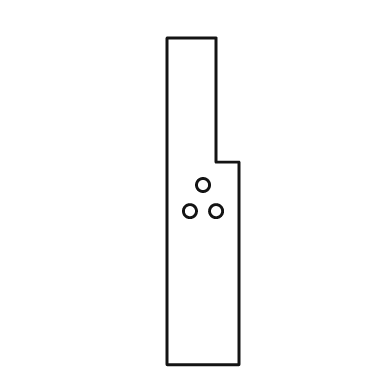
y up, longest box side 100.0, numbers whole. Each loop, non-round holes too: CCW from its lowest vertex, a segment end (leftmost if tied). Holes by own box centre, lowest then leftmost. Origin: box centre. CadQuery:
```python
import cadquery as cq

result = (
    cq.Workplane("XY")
    .moveTo(-11.0, -50.0)
    .lineTo(11.0, -50.0)
    .lineTo(11.0, 12.0)
    .lineTo(4.0, 12.0)
    .lineTo(4.0, 50.0)
    .lineTo(-11.0, 50.0)
    .close()
    .moveTo(-4.0, -3.0)
    .circle(2.0)
    .moveTo(4.0, -3.0)
    .circle(2.0)
    .moveTo(0.0, 5.0)
    .circle(2.0)
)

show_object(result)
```